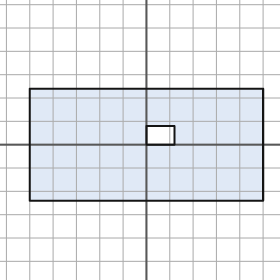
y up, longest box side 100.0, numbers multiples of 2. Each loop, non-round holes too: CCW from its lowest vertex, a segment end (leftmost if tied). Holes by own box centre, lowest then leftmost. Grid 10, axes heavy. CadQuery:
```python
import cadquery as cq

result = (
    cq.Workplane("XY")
    .moveTo(-50.0, -24.0)
    .lineTo(50.0, -24.0)
    .lineTo(50.0, 24.0)
    .lineTo(-50.0, 24.0)
    .close()
    .moveTo(0.0, 0.0)
    .lineTo(12.0, 0.0)
    .lineTo(12.0, 8.0)
    .lineTo(0.0, 8.0)
    .close()
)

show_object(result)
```